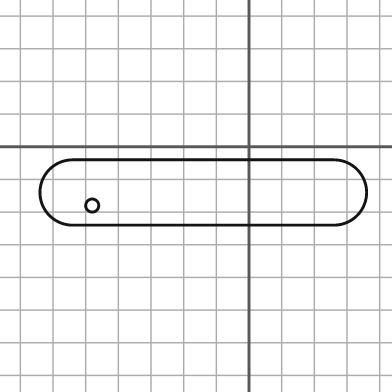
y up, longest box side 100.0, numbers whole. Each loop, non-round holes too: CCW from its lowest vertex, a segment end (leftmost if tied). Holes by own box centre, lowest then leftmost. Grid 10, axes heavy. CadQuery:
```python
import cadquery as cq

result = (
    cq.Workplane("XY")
    .moveTo(-54.0, -24.0)
    .lineTo(26.0, -24.0)
    .threePointArc((36.0, -14.0), (26.0, -4.0))
    .lineTo(-54.0, -4.0)
    .threePointArc((-64.0, -14.0), (-54.0, -24.0))
    .close()
    .moveTo(-48.0, -18.0)
    .circle(2.0)
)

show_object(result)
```